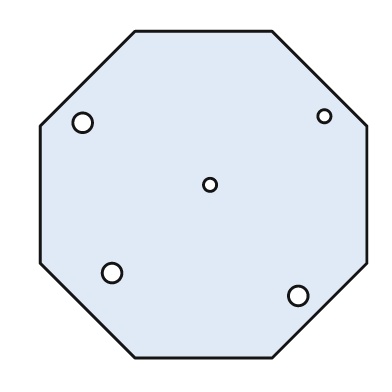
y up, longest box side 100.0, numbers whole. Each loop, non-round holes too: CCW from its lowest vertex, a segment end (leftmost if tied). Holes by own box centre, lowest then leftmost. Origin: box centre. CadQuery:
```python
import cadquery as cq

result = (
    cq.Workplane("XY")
    .moveTo(-21.0, -50.0)
    .lineTo(21.0, -50.0)
    .lineTo(50.0, -21.0)
    .lineTo(50.0, 21.0)
    .lineTo(21.0, 50.0)
    .lineTo(-21.0, 50.0)
    .lineTo(-50.0, 21.0)
    .lineTo(-50.0, -21.0)
    .close()
    .moveTo(29.0, -31.0)
    .circle(3.0)
    .moveTo(-28.0, -24.0)
    .circle(3.0)
    .moveTo(2.0, 3.0)
    .circle(2.0)
    .moveTo(-37.0, 22.0)
    .circle(3.0)
    .moveTo(37.0, 24.0)
    .circle(2.0)
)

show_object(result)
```